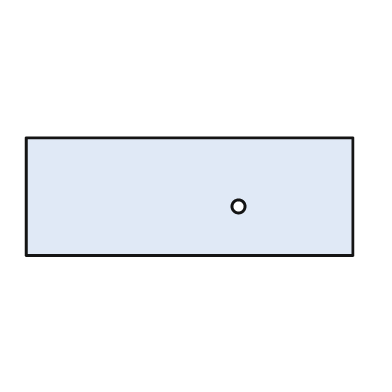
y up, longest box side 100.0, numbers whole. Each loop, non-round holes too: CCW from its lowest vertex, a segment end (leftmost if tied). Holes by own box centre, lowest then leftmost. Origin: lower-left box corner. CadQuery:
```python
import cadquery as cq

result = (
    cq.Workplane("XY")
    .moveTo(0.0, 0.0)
    .lineTo(100.0, 0.0)
    .lineTo(100.0, 36.0)
    .lineTo(0.0, 36.0)
    .close()
    .moveTo(65.0, 15.0)
    .circle(2.0)
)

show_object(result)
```